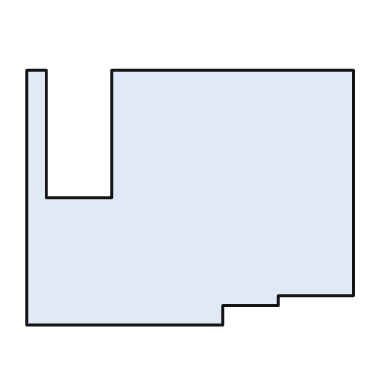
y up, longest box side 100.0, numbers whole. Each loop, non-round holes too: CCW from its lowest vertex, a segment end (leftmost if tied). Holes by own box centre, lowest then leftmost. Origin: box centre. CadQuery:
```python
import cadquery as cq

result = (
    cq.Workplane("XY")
    .moveTo(-50.0, -39.0)
    .lineTo(10.0, -39.0)
    .lineTo(10.0, -33.0)
    .lineTo(27.0, -33.0)
    .lineTo(27.0, -30.0)
    .lineTo(50.0, -30.0)
    .lineTo(50.0, 39.0)
    .lineTo(-24.0, 39.0)
    .lineTo(-24.0, 0.0)
    .lineTo(-44.0, 0.0)
    .lineTo(-44.0, 39.0)
    .lineTo(-50.0, 39.0)
    .close()
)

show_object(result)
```